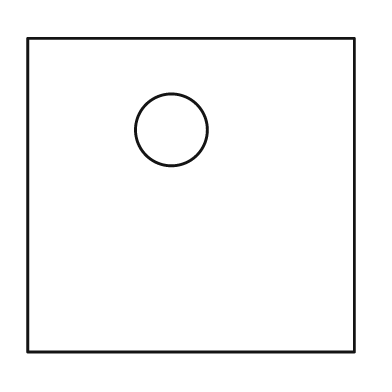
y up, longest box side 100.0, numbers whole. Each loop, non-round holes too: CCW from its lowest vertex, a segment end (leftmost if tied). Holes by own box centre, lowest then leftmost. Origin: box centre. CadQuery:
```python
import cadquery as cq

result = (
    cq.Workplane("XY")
    .moveTo(-50.0, -48.0)
    .lineTo(50.0, -48.0)
    .lineTo(50.0, 48.0)
    .lineTo(-50.0, 48.0)
    .close()
    .moveTo(-6.0, 20.0)
    .circle(11.0)
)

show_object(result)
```